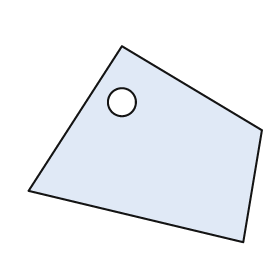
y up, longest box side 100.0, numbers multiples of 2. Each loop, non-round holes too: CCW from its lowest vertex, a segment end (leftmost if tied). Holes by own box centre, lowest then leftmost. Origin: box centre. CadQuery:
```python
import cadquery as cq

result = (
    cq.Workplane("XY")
    .moveTo(42.0, -42.0)
    .lineTo(50.0, 6.0)
    .lineTo(-10.0, 42.0)
    .lineTo(-50.0, -20.0)
    .close()
    .moveTo(-10.0, 18.0)
    .circle(6.0)
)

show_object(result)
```